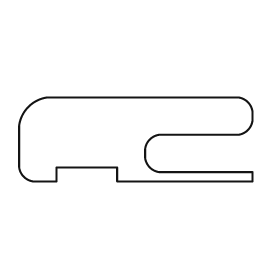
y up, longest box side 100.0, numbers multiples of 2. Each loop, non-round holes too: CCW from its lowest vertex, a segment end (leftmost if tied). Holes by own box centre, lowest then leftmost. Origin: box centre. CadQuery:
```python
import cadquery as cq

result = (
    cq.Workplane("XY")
    .moveTo(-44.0, -18.0)
    .lineTo(-34.0, -18.0)
    .lineTo(-34.0, -12.0)
    .lineTo(-8.0, -12.0)
    .lineTo(-8.0, -18.0)
    .lineTo(50.0, -18.0)
    .lineTo(50.0, -14.0)
    .lineTo(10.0, -14.0)
    .threePointArc((6.0, -12.0), (4.0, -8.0))
    .lineTo(4.0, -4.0)
    .threePointArc((6.0, 0.0), (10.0, 2.0))
    .lineTo(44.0, 2.0)
    .threePointArc((48.0, 4.0), (50.0, 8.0))
    .lineTo(50.0, 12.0)
    .threePointArc((48.0, 16.0), (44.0, 18.0))
    .lineTo(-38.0, 18.0)
    .threePointArc((-46.0, 14.0), (-50.0, 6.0))
    .lineTo(-50.0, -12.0)
    .threePointArc((-48.0, -16.0), (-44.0, -18.0))
    .close()
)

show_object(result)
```